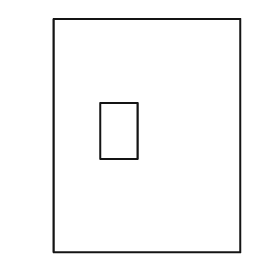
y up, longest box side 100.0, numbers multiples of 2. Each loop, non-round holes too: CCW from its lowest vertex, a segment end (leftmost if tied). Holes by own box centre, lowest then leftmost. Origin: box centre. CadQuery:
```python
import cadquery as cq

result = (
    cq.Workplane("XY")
    .moveTo(-40.0, -50.0)
    .lineTo(40.0, -50.0)
    .lineTo(40.0, 50.0)
    .lineTo(-40.0, 50.0)
    .close()
    .moveTo(-20.0, -10.0)
    .lineTo(-4.0, -10.0)
    .lineTo(-4.0, 14.0)
    .lineTo(-20.0, 14.0)
    .close()
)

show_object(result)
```